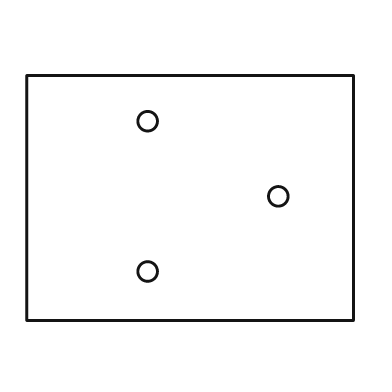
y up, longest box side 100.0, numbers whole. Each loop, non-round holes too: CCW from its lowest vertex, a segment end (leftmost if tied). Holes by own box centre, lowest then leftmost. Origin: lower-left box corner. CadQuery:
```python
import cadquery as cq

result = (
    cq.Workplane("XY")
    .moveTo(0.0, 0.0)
    .lineTo(100.0, 0.0)
    .lineTo(100.0, 75.0)
    .lineTo(0.0, 75.0)
    .close()
    .moveTo(37.0, 15.0)
    .circle(3.0)
    .moveTo(77.0, 38.0)
    .circle(3.0)
    .moveTo(37.0, 61.0)
    .circle(3.0)
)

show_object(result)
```